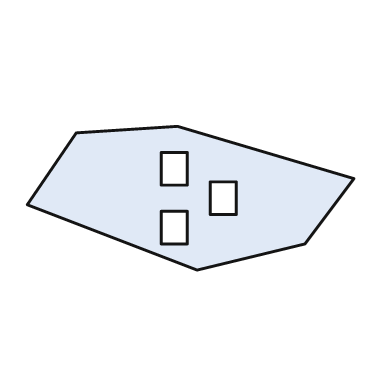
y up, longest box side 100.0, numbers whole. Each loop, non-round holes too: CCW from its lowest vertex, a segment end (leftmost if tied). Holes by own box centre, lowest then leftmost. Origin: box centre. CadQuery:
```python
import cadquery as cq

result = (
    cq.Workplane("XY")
    .moveTo(2.0, -22.0)
    .lineTo(35.0, -14.0)
    .lineTo(50.0, 6.0)
    .lineTo(-4.0, 22.0)
    .lineTo(-35.0, 20.0)
    .lineTo(-50.0, -2.0)
    .close()
    .moveTo(-9.0, -14.0)
    .lineTo(-1.0, -14.0)
    .lineTo(-1.0, -4.0)
    .lineTo(-9.0, -4.0)
    .close()
    .moveTo(6.0, -5.0)
    .lineTo(14.0, -5.0)
    .lineTo(14.0, 5.0)
    .lineTo(6.0, 5.0)
    .close()
    .moveTo(-9.0, 4.0)
    .lineTo(-1.0, 4.0)
    .lineTo(-1.0, 14.0)
    .lineTo(-9.0, 14.0)
    .close()
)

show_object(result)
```